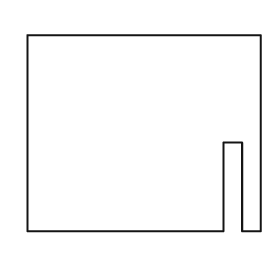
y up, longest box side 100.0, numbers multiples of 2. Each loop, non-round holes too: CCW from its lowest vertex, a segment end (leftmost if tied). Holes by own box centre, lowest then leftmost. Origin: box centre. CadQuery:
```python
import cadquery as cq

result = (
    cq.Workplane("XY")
    .moveTo(-50.0, -42.0)
    .lineTo(34.0, -42.0)
    .lineTo(34.0, -4.0)
    .lineTo(42.0, -4.0)
    .lineTo(42.0, -42.0)
    .lineTo(50.0, -42.0)
    .lineTo(50.0, 42.0)
    .lineTo(-50.0, 42.0)
    .close()
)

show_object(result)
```